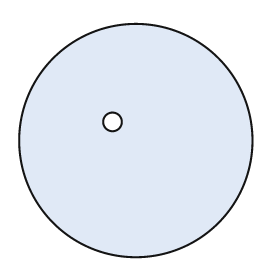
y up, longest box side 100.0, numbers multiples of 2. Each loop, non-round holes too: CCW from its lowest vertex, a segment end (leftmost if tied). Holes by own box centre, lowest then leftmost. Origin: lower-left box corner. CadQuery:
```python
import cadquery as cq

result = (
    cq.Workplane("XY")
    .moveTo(50.0, 50.0)
    .circle(50.0)
    .moveTo(40.0, 58.0)
    .circle(4.0)
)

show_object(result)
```